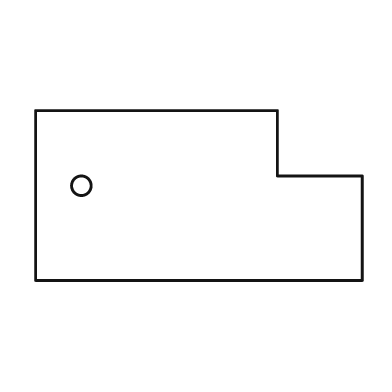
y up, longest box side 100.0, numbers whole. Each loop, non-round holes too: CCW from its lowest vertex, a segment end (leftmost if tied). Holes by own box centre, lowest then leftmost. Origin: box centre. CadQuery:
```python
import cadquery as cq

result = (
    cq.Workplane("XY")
    .moveTo(-50.0, -26.0)
    .lineTo(50.0, -26.0)
    .lineTo(50.0, 6.0)
    .lineTo(24.0, 6.0)
    .lineTo(24.0, 26.0)
    .lineTo(-50.0, 26.0)
    .close()
    .moveTo(-36.0, 3.0)
    .circle(3.0)
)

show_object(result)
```